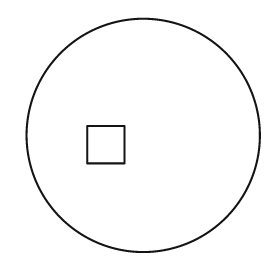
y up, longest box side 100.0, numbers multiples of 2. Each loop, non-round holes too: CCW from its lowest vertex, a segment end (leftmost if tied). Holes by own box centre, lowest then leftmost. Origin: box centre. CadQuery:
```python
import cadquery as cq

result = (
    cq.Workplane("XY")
    .moveTo(0.0, 0.0)
    .circle(50.0)
    .moveTo(-24.0, -12.0)
    .lineTo(-8.0, -12.0)
    .lineTo(-8.0, 4.0)
    .lineTo(-24.0, 4.0)
    .close()
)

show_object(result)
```